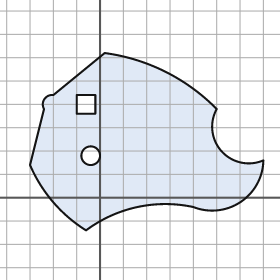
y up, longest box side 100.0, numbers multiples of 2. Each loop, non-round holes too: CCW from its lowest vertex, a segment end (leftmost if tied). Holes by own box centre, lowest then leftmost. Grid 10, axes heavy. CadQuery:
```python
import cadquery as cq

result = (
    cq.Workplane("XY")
    .moveTo(-6.0, -14.0)
    .threePointArc((16.0, -4.0), (40.0, -4.0))
    .threePointArc((60.0, -2.0), (70.0, 16.0))
    .threePointArc((52.0, 20.0), (50.0, 38.0))
    .threePointArc((28.0, 54.0), (2.0, 62.0))
    .lineTo(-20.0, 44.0)
    .threePointArc((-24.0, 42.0), (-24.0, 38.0))
    .lineTo(-30.0, 14.0)
    .threePointArc((-20.0, -2.0), (-6.0, -14.0))
    .close()
    .moveTo(-4.0, 18.0)
    .circle(4.0)
    .moveTo(-10.0, 36.0)
    .lineTo(-2.0, 36.0)
    .lineTo(-2.0, 44.0)
    .lineTo(-10.0, 44.0)
    .close()
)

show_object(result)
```